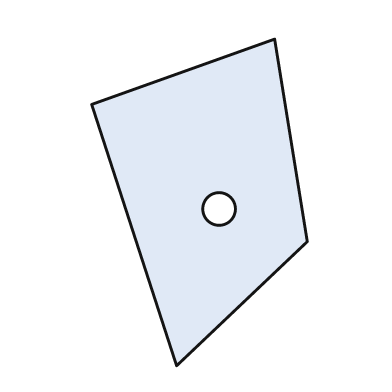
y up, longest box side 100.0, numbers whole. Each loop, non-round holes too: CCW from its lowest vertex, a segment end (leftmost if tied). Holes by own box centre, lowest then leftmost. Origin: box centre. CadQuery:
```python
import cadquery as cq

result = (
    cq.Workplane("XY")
    .moveTo(-7.0, -50.0)
    .lineTo(33.0, -12.0)
    .lineTo(23.0, 50.0)
    .lineTo(-33.0, 30.0)
    .close()
    .moveTo(6.0, -2.0)
    .circle(5.0)
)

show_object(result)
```